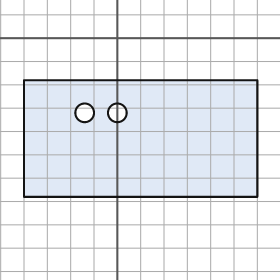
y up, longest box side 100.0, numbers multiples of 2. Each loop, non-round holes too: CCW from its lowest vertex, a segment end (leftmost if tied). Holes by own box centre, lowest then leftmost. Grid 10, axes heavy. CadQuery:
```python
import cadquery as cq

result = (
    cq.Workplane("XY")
    .moveTo(-40.0, -68.0)
    .lineTo(60.0, -68.0)
    .lineTo(60.0, -18.0)
    .lineTo(-40.0, -18.0)
    .close()
    .moveTo(-14.0, -32.0)
    .circle(4.0)
    .moveTo(0.0, -32.0)
    .circle(4.0)
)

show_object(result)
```